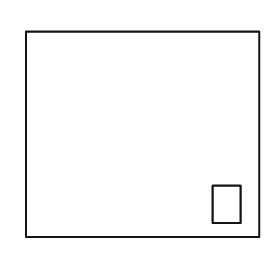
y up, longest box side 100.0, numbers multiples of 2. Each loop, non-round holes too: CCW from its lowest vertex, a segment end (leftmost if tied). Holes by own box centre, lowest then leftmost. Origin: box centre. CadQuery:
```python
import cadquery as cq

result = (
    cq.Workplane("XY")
    .moveTo(-50.0, -44.0)
    .lineTo(50.0, -44.0)
    .lineTo(50.0, 44.0)
    .lineTo(-50.0, 44.0)
    .close()
    .moveTo(30.0, -38.0)
    .lineTo(42.0, -38.0)
    .lineTo(42.0, -22.0)
    .lineTo(30.0, -22.0)
    .close()
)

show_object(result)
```